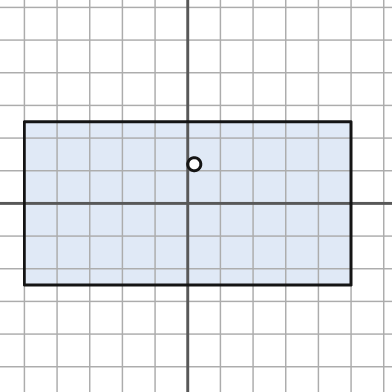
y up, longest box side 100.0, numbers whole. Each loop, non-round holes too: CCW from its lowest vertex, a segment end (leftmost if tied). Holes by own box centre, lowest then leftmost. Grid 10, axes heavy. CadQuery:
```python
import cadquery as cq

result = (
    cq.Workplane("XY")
    .moveTo(-50.0, -25.0)
    .lineTo(50.0, -25.0)
    .lineTo(50.0, 25.0)
    .lineTo(-50.0, 25.0)
    .close()
    .moveTo(2.0, 12.0)
    .circle(2.0)
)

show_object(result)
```